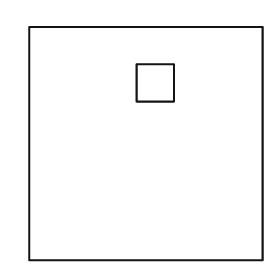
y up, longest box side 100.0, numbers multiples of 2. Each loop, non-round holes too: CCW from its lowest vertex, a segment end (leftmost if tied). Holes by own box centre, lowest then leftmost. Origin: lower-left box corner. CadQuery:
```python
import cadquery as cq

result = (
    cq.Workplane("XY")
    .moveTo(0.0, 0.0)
    .lineTo(100.0, 0.0)
    .lineTo(100.0, 100.0)
    .lineTo(0.0, 100.0)
    .close()
    .moveTo(46.0, 68.0)
    .lineTo(62.0, 68.0)
    .lineTo(62.0, 84.0)
    .lineTo(46.0, 84.0)
    .close()
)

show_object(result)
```